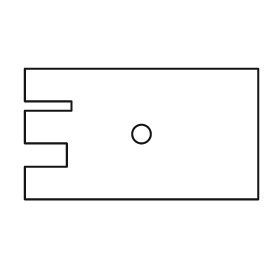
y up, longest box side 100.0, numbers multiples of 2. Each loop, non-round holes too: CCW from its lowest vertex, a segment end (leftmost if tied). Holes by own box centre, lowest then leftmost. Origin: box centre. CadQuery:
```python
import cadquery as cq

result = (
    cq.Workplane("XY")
    .moveTo(-50.0, -28.0)
    .lineTo(50.0, -28.0)
    .lineTo(50.0, 28.0)
    .lineTo(-50.0, 28.0)
    .lineTo(-50.0, 14.0)
    .lineTo(-30.0, 14.0)
    .lineTo(-30.0, 10.0)
    .lineTo(-50.0, 10.0)
    .lineTo(-50.0, -4.0)
    .lineTo(-32.0, -4.0)
    .lineTo(-32.0, -14.0)
    .lineTo(-50.0, -14.0)
    .close()
    .moveTo(0.0, 0.0)
    .circle(4.0)
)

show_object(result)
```